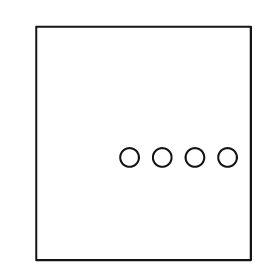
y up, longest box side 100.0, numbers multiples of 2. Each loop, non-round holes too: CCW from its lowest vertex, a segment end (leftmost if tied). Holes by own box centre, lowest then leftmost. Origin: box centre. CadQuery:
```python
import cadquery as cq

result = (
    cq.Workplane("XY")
    .moveTo(-46.0, -50.0)
    .lineTo(46.0, -50.0)
    .lineTo(46.0, 50.0)
    .lineTo(-46.0, 50.0)
    .close()
    .moveTo(-6.0, -6.0)
    .circle(4.0)
    .moveTo(8.0, -6.0)
    .circle(4.0)
    .moveTo(22.0, -6.0)
    .circle(4.0)
    .moveTo(36.0, -6.0)
    .circle(4.0)
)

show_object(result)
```